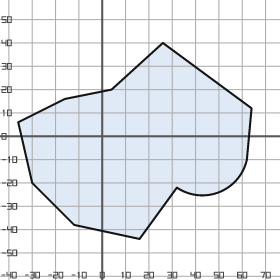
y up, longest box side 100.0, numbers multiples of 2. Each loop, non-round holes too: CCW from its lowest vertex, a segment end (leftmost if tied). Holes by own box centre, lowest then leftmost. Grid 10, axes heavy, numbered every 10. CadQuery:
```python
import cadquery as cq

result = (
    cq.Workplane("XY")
    .moveTo(16.0, -44.0)
    .lineTo(32.0, -22.0)
    .threePointArc((50.0, -24.0), (62.0, -10.0))
    .lineTo(64.0, 12.0)
    .lineTo(26.0, 40.0)
    .lineTo(4.0, 20.0)
    .lineTo(-16.0, 16.0)
    .lineTo(-36.0, 6.0)
    .lineTo(-30.0, -20.0)
    .lineTo(-12.0, -38.0)
    .close()
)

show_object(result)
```